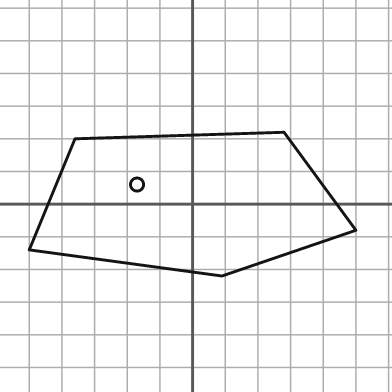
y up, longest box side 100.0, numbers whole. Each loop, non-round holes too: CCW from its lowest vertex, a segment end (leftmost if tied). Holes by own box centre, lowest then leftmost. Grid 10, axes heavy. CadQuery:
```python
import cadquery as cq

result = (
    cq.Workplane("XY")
    .moveTo(9.0, -22.0)
    .lineTo(50.0, -8.0)
    .lineTo(28.0, 22.0)
    .lineTo(-36.0, 20.0)
    .lineTo(-50.0, -14.0)
    .close()
    .moveTo(-17.0, 6.0)
    .circle(2.0)
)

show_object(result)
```